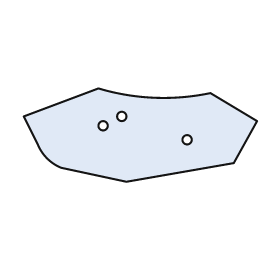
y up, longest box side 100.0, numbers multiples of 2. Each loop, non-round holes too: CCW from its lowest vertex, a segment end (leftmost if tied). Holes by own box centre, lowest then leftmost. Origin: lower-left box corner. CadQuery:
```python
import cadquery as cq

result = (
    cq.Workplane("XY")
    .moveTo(44.0, 0.0)
    .lineTo(90.0, 8.0)
    .lineTo(100.0, 26.0)
    .lineTo(80.0, 38.0)
    .threePointArc((56.0, 36.0), (32.0, 40.0))
    .lineTo(0.0, 28.0)
    .lineTo(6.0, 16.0)
    .threePointArc((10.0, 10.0), (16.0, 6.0))
    .close()
    .moveTo(70.0, 18.0)
    .circle(2.0)
    .moveTo(34.0, 24.0)
    .circle(2.0)
    .moveTo(42.0, 28.0)
    .circle(2.0)
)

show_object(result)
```